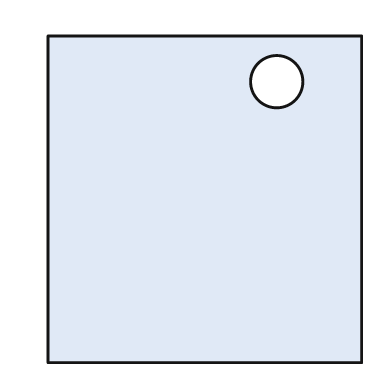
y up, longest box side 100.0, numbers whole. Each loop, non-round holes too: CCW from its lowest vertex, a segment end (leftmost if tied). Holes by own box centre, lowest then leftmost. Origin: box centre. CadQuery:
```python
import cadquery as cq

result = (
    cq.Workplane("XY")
    .moveTo(-48.0, -50.0)
    .lineTo(48.0, -50.0)
    .lineTo(48.0, 50.0)
    .lineTo(-48.0, 50.0)
    .close()
    .moveTo(22.0, 36.0)
    .circle(8.0)
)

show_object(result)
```